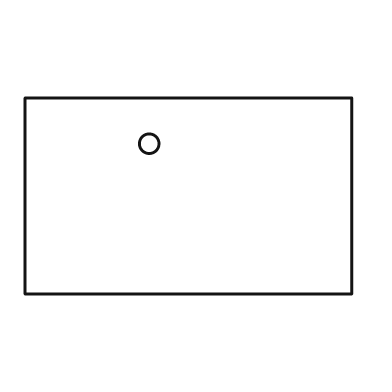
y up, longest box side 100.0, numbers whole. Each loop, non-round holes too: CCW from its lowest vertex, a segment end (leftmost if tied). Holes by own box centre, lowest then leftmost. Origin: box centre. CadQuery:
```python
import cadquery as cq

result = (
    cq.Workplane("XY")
    .moveTo(-50.0, -30.0)
    .lineTo(50.0, -30.0)
    .lineTo(50.0, 30.0)
    .lineTo(-50.0, 30.0)
    .close()
    .moveTo(-12.0, 16.0)
    .circle(3.0)
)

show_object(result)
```